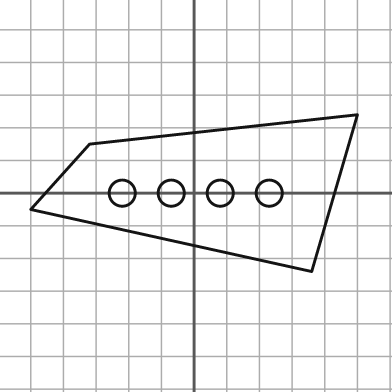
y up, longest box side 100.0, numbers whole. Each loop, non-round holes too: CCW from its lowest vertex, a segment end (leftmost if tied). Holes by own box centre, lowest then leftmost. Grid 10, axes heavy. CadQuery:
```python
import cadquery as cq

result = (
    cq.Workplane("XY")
    .moveTo(36.0, -24.0)
    .lineTo(50.0, 24.0)
    .lineTo(-32.0, 15.0)
    .lineTo(-50.0, -5.0)
    .close()
    .moveTo(-22.0, 0.0)
    .circle(4.0)
    .moveTo(-7.0, 0.0)
    .circle(4.0)
    .moveTo(8.0, 0.0)
    .circle(4.0)
    .moveTo(23.0, 0.0)
    .circle(4.0)
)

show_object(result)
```